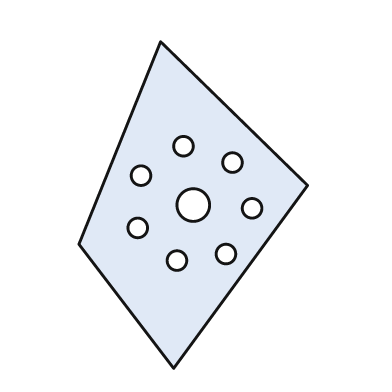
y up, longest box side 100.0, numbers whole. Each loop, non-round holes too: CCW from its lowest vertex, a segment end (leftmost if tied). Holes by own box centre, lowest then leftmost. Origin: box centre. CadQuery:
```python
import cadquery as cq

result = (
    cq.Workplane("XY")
    .moveTo(-6.0, -50.0)
    .lineTo(35.0, 6.0)
    .lineTo(-10.0, 50.0)
    .lineTo(-35.0, -12.0)
    .close()
    .moveTo(-5.0, -17.0)
    .circle(3.0)
    .moveTo(10.0, -15.0)
    .circle(3.0)
    .moveTo(-17.0, -7.0)
    .circle(3.0)
    .moveTo(18.0, -1.0)
    .circle(3.0)
    .moveTo(0.0, 0.0)
    .circle(5.0)
    .moveTo(-16.0, 9.0)
    .circle(3.0)
    .moveTo(12.0, 13.0)
    .circle(3.0)
    .moveTo(-3.0, 18.0)
    .circle(3.0)
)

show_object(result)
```